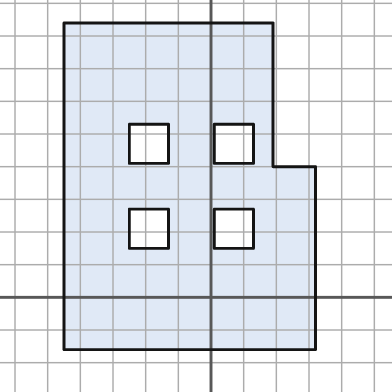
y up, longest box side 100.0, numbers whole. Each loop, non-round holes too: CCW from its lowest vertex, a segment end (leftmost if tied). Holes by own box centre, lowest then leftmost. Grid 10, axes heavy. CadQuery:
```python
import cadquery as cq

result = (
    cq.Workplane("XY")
    .moveTo(-45.0, -16.0)
    .lineTo(32.0, -16.0)
    .lineTo(32.0, 40.0)
    .lineTo(19.0, 40.0)
    .lineTo(19.0, 84.0)
    .lineTo(-45.0, 84.0)
    .close()
    .moveTo(-25.0, 15.0)
    .lineTo(-13.0, 15.0)
    .lineTo(-13.0, 27.0)
    .lineTo(-25.0, 27.0)
    .close()
    .moveTo(1.0, 15.0)
    .lineTo(13.0, 15.0)
    .lineTo(13.0, 27.0)
    .lineTo(1.0, 27.0)
    .close()
    .moveTo(-25.0, 41.0)
    .lineTo(-13.0, 41.0)
    .lineTo(-13.0, 53.0)
    .lineTo(-25.0, 53.0)
    .close()
    .moveTo(1.0, 41.0)
    .lineTo(13.0, 41.0)
    .lineTo(13.0, 53.0)
    .lineTo(1.0, 53.0)
    .close()
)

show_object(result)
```